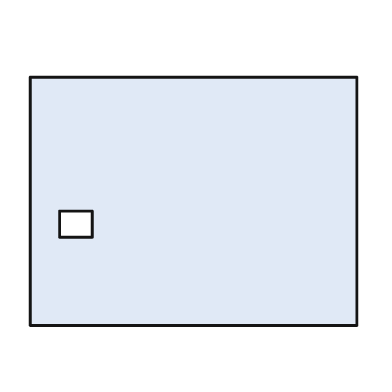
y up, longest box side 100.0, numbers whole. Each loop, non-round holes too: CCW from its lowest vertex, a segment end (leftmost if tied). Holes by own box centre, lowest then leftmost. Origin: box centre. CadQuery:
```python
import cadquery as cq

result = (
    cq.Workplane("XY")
    .moveTo(-50.0, -38.0)
    .lineTo(50.0, -38.0)
    .lineTo(50.0, 38.0)
    .lineTo(-50.0, 38.0)
    .close()
    .moveTo(-41.0, -11.0)
    .lineTo(-31.0, -11.0)
    .lineTo(-31.0, -3.0)
    .lineTo(-41.0, -3.0)
    .close()
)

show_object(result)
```